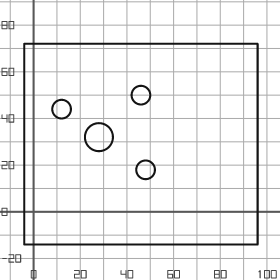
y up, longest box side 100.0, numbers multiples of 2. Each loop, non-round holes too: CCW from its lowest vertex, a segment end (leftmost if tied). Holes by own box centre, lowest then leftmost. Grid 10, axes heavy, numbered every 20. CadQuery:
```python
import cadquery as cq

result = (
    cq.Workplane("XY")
    .moveTo(-4.0, -14.0)
    .lineTo(96.0, -14.0)
    .lineTo(96.0, 72.0)
    .lineTo(-4.0, 72.0)
    .close()
    .moveTo(48.0, 18.0)
    .circle(4.0)
    .moveTo(28.0, 32.0)
    .circle(6.0)
    .moveTo(12.0, 44.0)
    .circle(4.0)
    .moveTo(46.0, 50.0)
    .circle(4.0)
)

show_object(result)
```